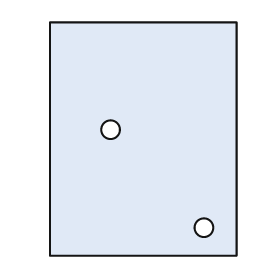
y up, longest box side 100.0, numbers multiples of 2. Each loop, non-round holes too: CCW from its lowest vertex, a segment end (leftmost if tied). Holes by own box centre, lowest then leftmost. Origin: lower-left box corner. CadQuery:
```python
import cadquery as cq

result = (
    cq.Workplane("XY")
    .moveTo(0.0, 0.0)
    .lineTo(80.0, 0.0)
    .lineTo(80.0, 100.0)
    .lineTo(0.0, 100.0)
    .close()
    .moveTo(66.0, 12.0)
    .circle(4.0)
    .moveTo(26.0, 54.0)
    .circle(4.0)
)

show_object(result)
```